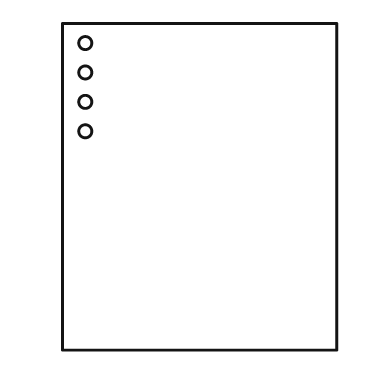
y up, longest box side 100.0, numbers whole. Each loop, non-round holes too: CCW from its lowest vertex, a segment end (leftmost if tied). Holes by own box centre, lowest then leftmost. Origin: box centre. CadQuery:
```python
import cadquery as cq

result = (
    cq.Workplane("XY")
    .moveTo(-42.0, -50.0)
    .lineTo(42.0, -50.0)
    .lineTo(42.0, 50.0)
    .lineTo(-42.0, 50.0)
    .close()
    .moveTo(-35.0, 17.0)
    .circle(2.0)
    .moveTo(-35.0, 26.0)
    .circle(2.0)
    .moveTo(-35.0, 35.0)
    .circle(2.0)
    .moveTo(-35.0, 44.0)
    .circle(2.0)
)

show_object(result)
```